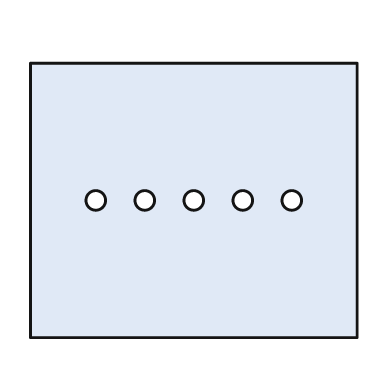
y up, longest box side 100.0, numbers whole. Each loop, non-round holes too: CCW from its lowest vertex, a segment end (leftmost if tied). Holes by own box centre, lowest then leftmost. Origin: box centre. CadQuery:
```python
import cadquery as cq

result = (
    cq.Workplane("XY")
    .moveTo(-50.0, -42.0)
    .lineTo(50.0, -42.0)
    .lineTo(50.0, 42.0)
    .lineTo(-50.0, 42.0)
    .close()
    .moveTo(-30.0, 0.0)
    .circle(3.0)
    .moveTo(-15.0, 0.0)
    .circle(3.0)
    .moveTo(0.0, 0.0)
    .circle(3.0)
    .moveTo(15.0, 0.0)
    .circle(3.0)
    .moveTo(30.0, 0.0)
    .circle(3.0)
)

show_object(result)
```